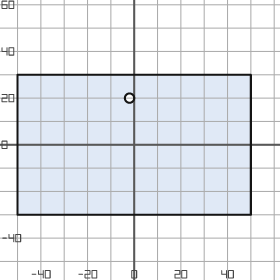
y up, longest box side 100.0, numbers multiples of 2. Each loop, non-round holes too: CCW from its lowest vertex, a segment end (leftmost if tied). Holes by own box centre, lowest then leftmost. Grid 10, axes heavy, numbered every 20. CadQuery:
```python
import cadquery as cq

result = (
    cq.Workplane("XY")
    .moveTo(-50.0, -30.0)
    .lineTo(50.0, -30.0)
    .lineTo(50.0, 30.0)
    .lineTo(-50.0, 30.0)
    .close()
    .moveTo(-2.0, 20.0)
    .circle(2.0)
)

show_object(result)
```